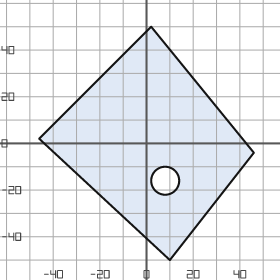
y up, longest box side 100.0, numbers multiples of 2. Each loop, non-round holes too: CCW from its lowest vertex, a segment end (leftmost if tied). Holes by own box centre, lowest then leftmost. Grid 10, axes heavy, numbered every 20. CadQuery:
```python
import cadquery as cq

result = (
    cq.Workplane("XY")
    .moveTo(10.0, -50.0)
    .lineTo(46.0, -4.0)
    .lineTo(2.0, 50.0)
    .lineTo(-46.0, 2.0)
    .close()
    .moveTo(8.0, -16.0)
    .circle(6.0)
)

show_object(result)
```